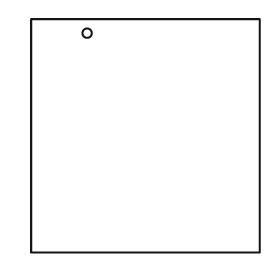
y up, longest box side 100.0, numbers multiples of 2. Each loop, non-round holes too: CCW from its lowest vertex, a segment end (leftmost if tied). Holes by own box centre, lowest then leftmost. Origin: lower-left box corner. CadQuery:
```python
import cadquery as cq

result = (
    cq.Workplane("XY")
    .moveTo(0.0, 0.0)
    .lineTo(98.0, 0.0)
    .lineTo(98.0, 100.0)
    .lineTo(0.0, 100.0)
    .close()
    .moveTo(24.0, 94.0)
    .circle(2.0)
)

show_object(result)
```